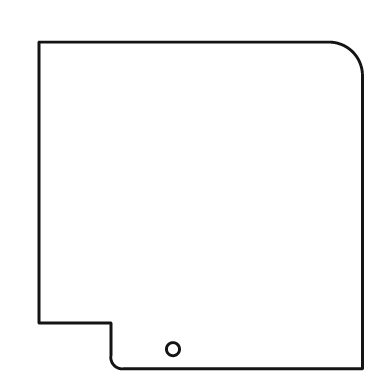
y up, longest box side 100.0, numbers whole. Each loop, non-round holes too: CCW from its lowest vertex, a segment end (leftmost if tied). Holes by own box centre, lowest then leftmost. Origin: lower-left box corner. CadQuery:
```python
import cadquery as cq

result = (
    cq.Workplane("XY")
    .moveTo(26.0, 0.0)
    .lineTo(99.0, 0.0)
    .lineTo(99.0, 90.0)
    .threePointArc((96.0, 97.0), (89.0, 100.0))
    .lineTo(0.0, 100.0)
    .lineTo(0.0, 14.0)
    .lineTo(22.0, 14.0)
    .lineTo(22.0, 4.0)
    .threePointArc((23.0, 1.0), (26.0, 0.0))
    .close()
    .moveTo(41.0, 6.0)
    .circle(2.0)
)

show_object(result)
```